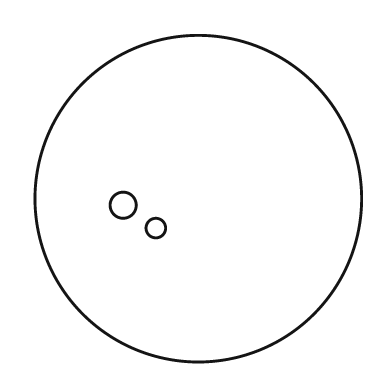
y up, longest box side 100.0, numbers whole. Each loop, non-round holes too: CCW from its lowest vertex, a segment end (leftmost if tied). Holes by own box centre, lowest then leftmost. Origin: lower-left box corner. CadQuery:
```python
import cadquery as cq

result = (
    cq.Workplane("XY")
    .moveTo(50.0, 50.0)
    .circle(50.0)
    .moveTo(37.0, 41.0)
    .circle(3.0)
    .moveTo(27.0, 48.0)
    .circle(4.0)
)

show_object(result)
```